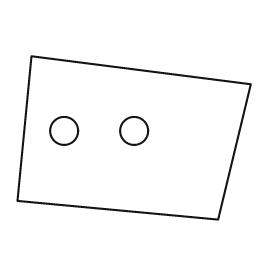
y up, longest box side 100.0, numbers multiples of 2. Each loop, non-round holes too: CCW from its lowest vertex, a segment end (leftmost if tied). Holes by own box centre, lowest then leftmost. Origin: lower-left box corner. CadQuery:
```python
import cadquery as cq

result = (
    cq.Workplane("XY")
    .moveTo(86.0, 0.0)
    .lineTo(100.0, 58.0)
    .lineTo(6.0, 70.0)
    .lineTo(0.0, 8.0)
    .close()
    .moveTo(20.0, 38.0)
    .circle(6.0)
    .moveTo(50.0, 38.0)
    .circle(6.0)
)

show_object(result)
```